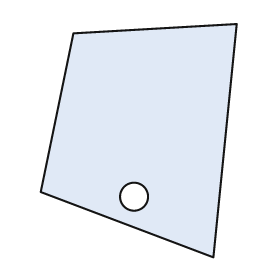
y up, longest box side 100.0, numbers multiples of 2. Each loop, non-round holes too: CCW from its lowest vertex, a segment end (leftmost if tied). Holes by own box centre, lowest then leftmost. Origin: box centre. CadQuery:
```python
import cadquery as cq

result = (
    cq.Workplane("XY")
    .moveTo(32.0, -50.0)
    .lineTo(42.0, 50.0)
    .lineTo(-28.0, 46.0)
    .lineTo(-42.0, -22.0)
    .close()
    .moveTo(-2.0, -24.0)
    .circle(6.0)
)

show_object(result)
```